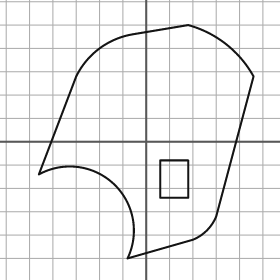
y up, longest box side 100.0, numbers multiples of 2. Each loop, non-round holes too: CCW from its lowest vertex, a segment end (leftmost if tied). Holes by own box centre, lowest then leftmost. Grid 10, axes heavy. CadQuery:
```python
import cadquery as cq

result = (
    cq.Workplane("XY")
    .moveTo(-8.0, -50.0)
    .lineTo(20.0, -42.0)
    .threePointArc((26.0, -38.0), (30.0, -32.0))
    .lineTo(46.0, 28.0)
    .threePointArc((34.0, 42.0), (18.0, 50.0))
    .lineTo(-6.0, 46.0)
    .threePointArc((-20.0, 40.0), (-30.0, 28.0))
    .lineTo(-46.0, -14.0)
    .threePointArc((-14.0, -18.0), (-8.0, -50.0))
    .close()
    .moveTo(6.0, -24.0)
    .lineTo(18.0, -24.0)
    .lineTo(18.0, -8.0)
    .lineTo(6.0, -8.0)
    .close()
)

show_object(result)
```